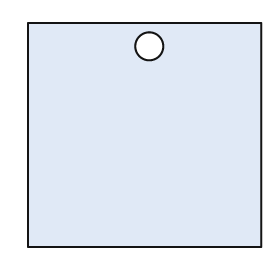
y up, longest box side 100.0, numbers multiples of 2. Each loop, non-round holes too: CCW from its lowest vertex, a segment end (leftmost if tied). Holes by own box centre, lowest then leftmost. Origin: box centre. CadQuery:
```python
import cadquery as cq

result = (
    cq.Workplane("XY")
    .moveTo(-50.0, -48.0)
    .lineTo(50.0, -48.0)
    .lineTo(50.0, 48.0)
    .lineTo(-50.0, 48.0)
    .close()
    .moveTo(2.0, 38.0)
    .circle(6.0)
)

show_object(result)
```